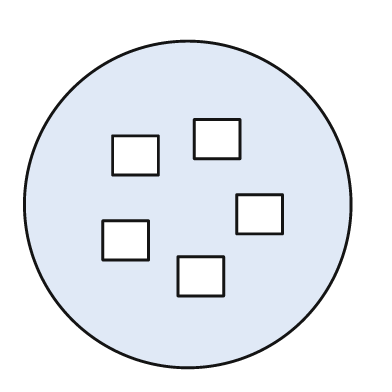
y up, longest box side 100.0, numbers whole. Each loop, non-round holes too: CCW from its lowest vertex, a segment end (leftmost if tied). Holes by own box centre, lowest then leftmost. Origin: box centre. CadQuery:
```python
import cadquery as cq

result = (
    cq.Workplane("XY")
    .moveTo(0.0, 0.0)
    .circle(50.0)
    .moveTo(-3.0, -28.0)
    .lineTo(11.0, -28.0)
    .lineTo(11.0, -16.0)
    .lineTo(-3.0, -16.0)
    .close()
    .moveTo(-26.0, -17.0)
    .lineTo(-12.0, -17.0)
    .lineTo(-12.0, -5.0)
    .lineTo(-26.0, -5.0)
    .close()
    .moveTo(15.0, -9.0)
    .lineTo(29.0, -9.0)
    .lineTo(29.0, 3.0)
    .lineTo(15.0, 3.0)
    .close()
    .moveTo(-23.0, 9.0)
    .lineTo(-9.0, 9.0)
    .lineTo(-9.0, 21.0)
    .lineTo(-23.0, 21.0)
    .close()
    .moveTo(2.0, 14.0)
    .lineTo(16.0, 14.0)
    .lineTo(16.0, 26.0)
    .lineTo(2.0, 26.0)
    .close()
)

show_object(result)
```